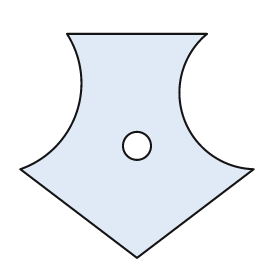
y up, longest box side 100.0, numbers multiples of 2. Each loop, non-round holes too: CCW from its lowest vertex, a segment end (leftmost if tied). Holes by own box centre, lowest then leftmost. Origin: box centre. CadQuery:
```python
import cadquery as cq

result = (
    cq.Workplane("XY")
    .moveTo(0.0, -48.0)
    .lineTo(50.0, -10.0)
    .threePointArc((20.0, 12.0), (30.0, 48.0))
    .lineTo(-30.0, 48.0)
    .threePointArc((-26.0, 14.0), (-50.0, -10.0))
    .close()
    .moveTo(0.0, 0.0)
    .circle(6.0)
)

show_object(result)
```